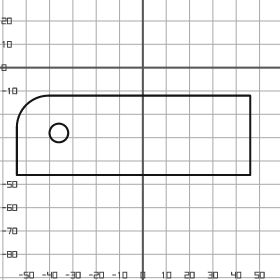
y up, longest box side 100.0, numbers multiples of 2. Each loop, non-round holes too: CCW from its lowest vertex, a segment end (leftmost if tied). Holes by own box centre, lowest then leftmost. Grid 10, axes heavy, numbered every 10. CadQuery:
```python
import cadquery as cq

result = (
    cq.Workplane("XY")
    .moveTo(-54.0, -46.0)
    .lineTo(46.0, -46.0)
    .lineTo(46.0, -12.0)
    .lineTo(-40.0, -12.0)
    .threePointArc((-50.0, -16.0), (-54.0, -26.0))
    .close()
    .moveTo(-36.0, -28.0)
    .circle(4.0)
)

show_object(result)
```